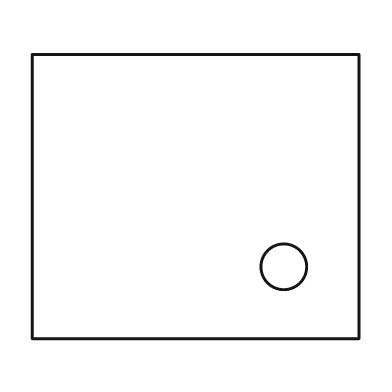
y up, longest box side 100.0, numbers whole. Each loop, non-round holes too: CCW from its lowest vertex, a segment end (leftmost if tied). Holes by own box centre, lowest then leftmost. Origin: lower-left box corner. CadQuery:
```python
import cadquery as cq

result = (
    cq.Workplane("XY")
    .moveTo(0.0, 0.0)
    .lineTo(100.0, 0.0)
    .lineTo(100.0, 87.0)
    .lineTo(0.0, 87.0)
    .close()
    .moveTo(77.0, 22.0)
    .circle(7.0)
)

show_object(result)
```